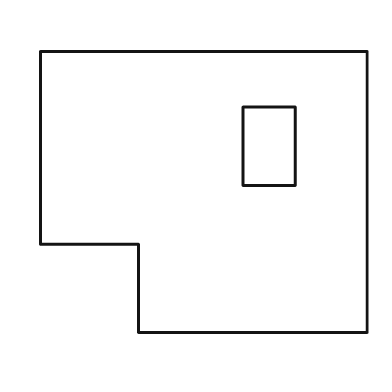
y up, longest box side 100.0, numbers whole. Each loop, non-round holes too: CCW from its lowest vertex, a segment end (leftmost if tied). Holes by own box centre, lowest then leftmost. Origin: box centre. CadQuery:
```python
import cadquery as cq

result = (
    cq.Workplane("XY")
    .moveTo(-20.0, -43.0)
    .lineTo(50.0, -43.0)
    .lineTo(50.0, 43.0)
    .lineTo(-50.0, 43.0)
    .lineTo(-50.0, -16.0)
    .lineTo(-20.0, -16.0)
    .close()
    .moveTo(12.0, 2.0)
    .lineTo(28.0, 2.0)
    .lineTo(28.0, 26.0)
    .lineTo(12.0, 26.0)
    .close()
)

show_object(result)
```